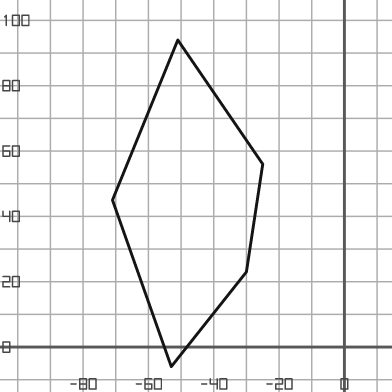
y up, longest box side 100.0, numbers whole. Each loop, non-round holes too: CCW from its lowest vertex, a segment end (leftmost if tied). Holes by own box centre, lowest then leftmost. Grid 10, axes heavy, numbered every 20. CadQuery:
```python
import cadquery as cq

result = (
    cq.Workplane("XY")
    .moveTo(-53.0, -6.0)
    .lineTo(-30.0, 23.0)
    .lineTo(-25.0, 56.0)
    .lineTo(-51.0, 94.0)
    .lineTo(-71.0, 45.0)
    .close()
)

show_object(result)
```